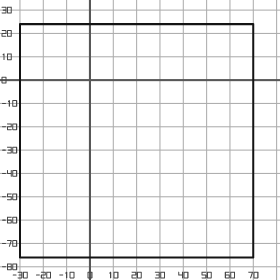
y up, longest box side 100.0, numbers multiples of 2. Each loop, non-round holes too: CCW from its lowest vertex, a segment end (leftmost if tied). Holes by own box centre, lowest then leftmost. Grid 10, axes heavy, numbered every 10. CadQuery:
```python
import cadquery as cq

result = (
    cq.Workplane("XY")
    .moveTo(-30.0, -76.0)
    .lineTo(70.0, -76.0)
    .lineTo(70.0, 24.0)
    .lineTo(-30.0, 24.0)
    .close()
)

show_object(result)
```